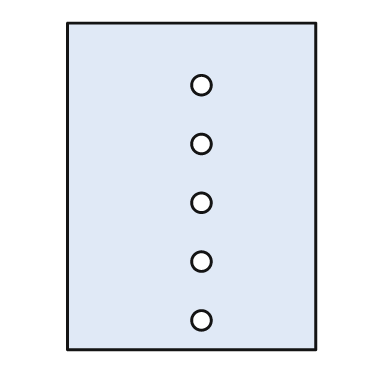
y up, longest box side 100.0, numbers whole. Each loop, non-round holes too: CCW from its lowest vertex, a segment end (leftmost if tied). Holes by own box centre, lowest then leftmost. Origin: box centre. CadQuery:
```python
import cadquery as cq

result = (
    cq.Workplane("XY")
    .moveTo(-38.0, -50.0)
    .lineTo(38.0, -50.0)
    .lineTo(38.0, 50.0)
    .lineTo(-38.0, 50.0)
    .close()
    .moveTo(3.0, -41.0)
    .circle(3.0)
    .moveTo(3.0, -23.0)
    .circle(3.0)
    .moveTo(3.0, -5.0)
    .circle(3.0)
    .moveTo(3.0, 13.0)
    .circle(3.0)
    .moveTo(3.0, 31.0)
    .circle(3.0)
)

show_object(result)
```